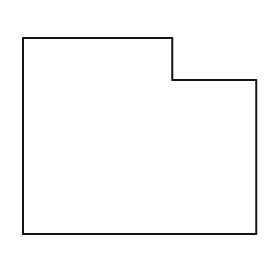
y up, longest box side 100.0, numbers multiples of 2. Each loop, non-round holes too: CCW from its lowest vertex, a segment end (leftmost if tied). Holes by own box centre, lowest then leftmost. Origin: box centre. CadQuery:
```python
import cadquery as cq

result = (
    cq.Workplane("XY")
    .moveTo(-50.0, -42.0)
    .lineTo(50.0, -42.0)
    .lineTo(50.0, 24.0)
    .lineTo(14.0, 24.0)
    .lineTo(14.0, 42.0)
    .lineTo(-50.0, 42.0)
    .close()
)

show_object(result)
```